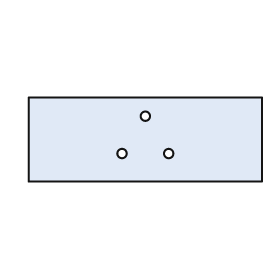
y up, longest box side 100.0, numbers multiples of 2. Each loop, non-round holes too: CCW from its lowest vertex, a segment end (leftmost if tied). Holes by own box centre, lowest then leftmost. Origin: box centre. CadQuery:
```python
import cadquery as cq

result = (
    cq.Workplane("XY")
    .moveTo(-50.0, -18.0)
    .lineTo(50.0, -18.0)
    .lineTo(50.0, 18.0)
    .lineTo(-50.0, 18.0)
    .close()
    .moveTo(-10.0, -6.0)
    .circle(2.0)
    .moveTo(10.0, -6.0)
    .circle(2.0)
    .moveTo(0.0, 10.0)
    .circle(2.0)
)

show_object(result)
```